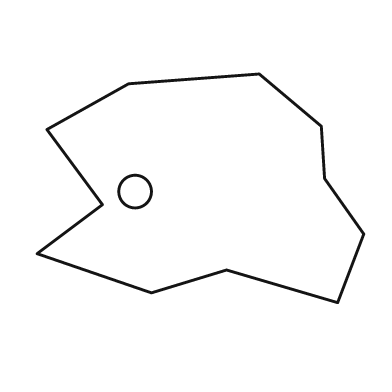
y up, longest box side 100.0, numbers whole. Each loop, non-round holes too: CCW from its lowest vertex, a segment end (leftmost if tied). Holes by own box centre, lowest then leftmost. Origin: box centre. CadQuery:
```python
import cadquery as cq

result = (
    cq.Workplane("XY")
    .moveTo(42.0, -35.0)
    .lineTo(50.0, -14.0)
    .lineTo(38.0, 3.0)
    .lineTo(37.0, 19.0)
    .lineTo(18.0, 35.0)
    .lineTo(-22.0, 32.0)
    .lineTo(-47.0, 18.0)
    .lineTo(-30.0, -5.0)
    .lineTo(-50.0, -20.0)
    .lineTo(-15.0, -32.0)
    .lineTo(8.0, -25.0)
    .close()
    .moveTo(-20.0, -1.0)
    .circle(5.0)
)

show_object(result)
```